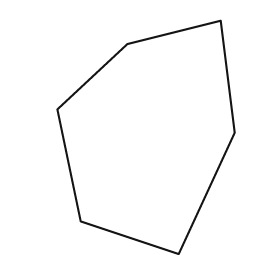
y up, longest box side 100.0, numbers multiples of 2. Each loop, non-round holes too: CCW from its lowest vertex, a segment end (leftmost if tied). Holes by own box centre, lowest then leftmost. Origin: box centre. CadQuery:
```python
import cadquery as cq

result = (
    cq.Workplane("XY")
    .moveTo(14.0, -50.0)
    .lineTo(38.0, 2.0)
    .lineTo(32.0, 50.0)
    .lineTo(-8.0, 40.0)
    .lineTo(-38.0, 12.0)
    .lineTo(-28.0, -36.0)
    .close()
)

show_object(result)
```